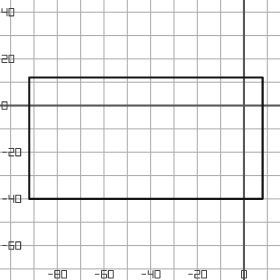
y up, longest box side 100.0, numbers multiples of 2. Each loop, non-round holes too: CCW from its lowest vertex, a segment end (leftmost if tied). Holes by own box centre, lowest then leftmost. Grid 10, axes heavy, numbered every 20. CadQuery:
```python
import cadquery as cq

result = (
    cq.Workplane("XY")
    .moveTo(-92.0, -40.0)
    .lineTo(8.0, -40.0)
    .lineTo(8.0, 12.0)
    .lineTo(-92.0, 12.0)
    .close()
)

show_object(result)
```